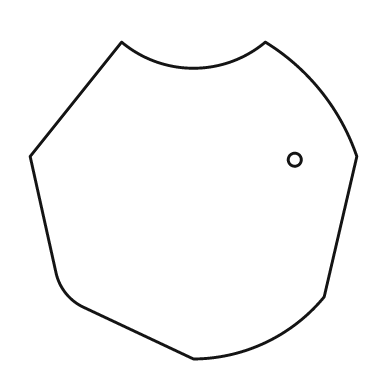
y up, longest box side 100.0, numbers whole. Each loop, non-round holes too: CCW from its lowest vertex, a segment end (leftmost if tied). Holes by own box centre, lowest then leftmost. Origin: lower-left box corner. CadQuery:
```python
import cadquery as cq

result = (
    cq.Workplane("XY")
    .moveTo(50.0, 0.0)
    .threePointArc((72.0, 5.0), (90.0, 19.0))
    .lineTo(100.0, 62.0)
    .threePointArc((89.0, 82.0), (72.0, 97.0))
    .threePointArc((50.0, 89.0), (28.0, 97.0))
    .lineTo(0.0, 62.0)
    .lineTo(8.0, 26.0)
    .threePointArc((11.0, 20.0), (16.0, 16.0))
    .close()
    .moveTo(81.0, 61.0)
    .circle(2.0)
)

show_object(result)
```